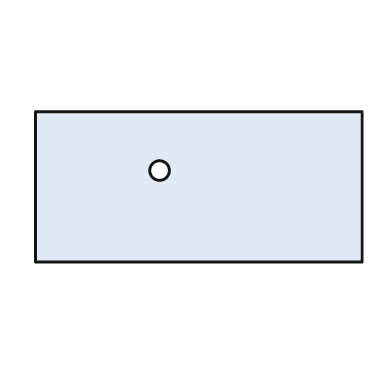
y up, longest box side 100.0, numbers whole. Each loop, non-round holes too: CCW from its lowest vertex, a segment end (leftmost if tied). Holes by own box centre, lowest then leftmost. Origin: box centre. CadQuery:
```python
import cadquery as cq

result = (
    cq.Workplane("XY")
    .moveTo(-50.0, -23.0)
    .lineTo(50.0, -23.0)
    .lineTo(50.0, 23.0)
    .lineTo(-50.0, 23.0)
    .close()
    .moveTo(-12.0, 5.0)
    .circle(3.0)
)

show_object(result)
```